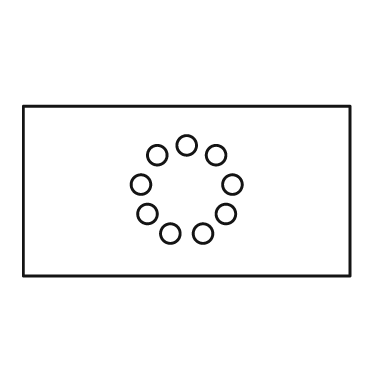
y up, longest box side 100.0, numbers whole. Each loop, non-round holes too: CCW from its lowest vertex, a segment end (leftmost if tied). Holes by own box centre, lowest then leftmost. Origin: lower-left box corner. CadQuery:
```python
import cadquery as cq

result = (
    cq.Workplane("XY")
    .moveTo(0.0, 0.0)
    .lineTo(100.0, 0.0)
    .lineTo(100.0, 52.0)
    .lineTo(0.0, 52.0)
    .close()
    .moveTo(45.0, 13.0)
    .circle(3.0)
    .moveTo(55.0, 13.0)
    .circle(3.0)
    .moveTo(38.0, 19.0)
    .circle(3.0)
    .moveTo(62.0, 19.0)
    .circle(3.0)
    .moveTo(36.0, 28.0)
    .circle(3.0)
    .moveTo(64.0, 28.0)
    .circle(3.0)
    .moveTo(41.0, 37.0)
    .circle(3.0)
    .moveTo(59.0, 37.0)
    .circle(3.0)
    .moveTo(50.0, 40.0)
    .circle(3.0)
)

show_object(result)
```